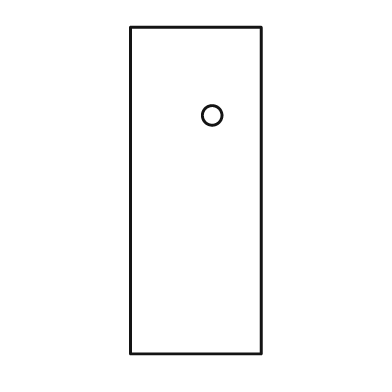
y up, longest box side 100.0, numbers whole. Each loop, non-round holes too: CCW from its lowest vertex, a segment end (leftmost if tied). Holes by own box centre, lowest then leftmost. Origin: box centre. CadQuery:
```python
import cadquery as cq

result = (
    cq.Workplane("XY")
    .moveTo(-20.0, -50.0)
    .lineTo(20.0, -50.0)
    .lineTo(20.0, 50.0)
    .lineTo(-20.0, 50.0)
    .close()
    .moveTo(5.0, 23.0)
    .circle(3.0)
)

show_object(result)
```